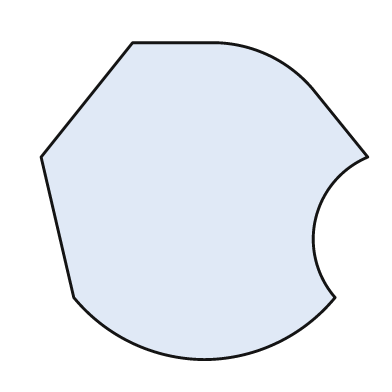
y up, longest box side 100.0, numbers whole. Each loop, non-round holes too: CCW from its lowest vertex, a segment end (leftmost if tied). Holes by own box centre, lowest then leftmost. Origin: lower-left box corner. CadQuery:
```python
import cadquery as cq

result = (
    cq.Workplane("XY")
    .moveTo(50.0, 0.0)
    .threePointArc((72.0, 5.0), (90.0, 19.0))
    .threePointArc((84.0, 43.0), (100.0, 62.0))
    .lineTo(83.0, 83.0)
    .threePointArc((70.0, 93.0), (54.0, 97.0))
    .lineTo(28.0, 97.0)
    .lineTo(0.0, 62.0)
    .lineTo(10.0, 19.0)
    .threePointArc((28.0, 5.0), (50.0, 0.0))
    .close()
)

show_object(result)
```